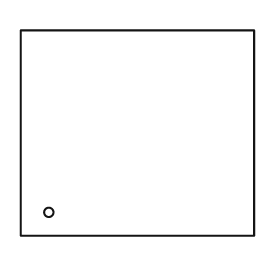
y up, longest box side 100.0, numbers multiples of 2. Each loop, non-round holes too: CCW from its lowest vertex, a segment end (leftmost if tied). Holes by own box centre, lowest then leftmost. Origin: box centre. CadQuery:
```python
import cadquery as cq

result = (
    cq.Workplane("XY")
    .moveTo(-50.0, -44.0)
    .lineTo(50.0, -44.0)
    .lineTo(50.0, 44.0)
    .lineTo(-50.0, 44.0)
    .close()
    .moveTo(-38.0, -34.0)
    .circle(2.0)
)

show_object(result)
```